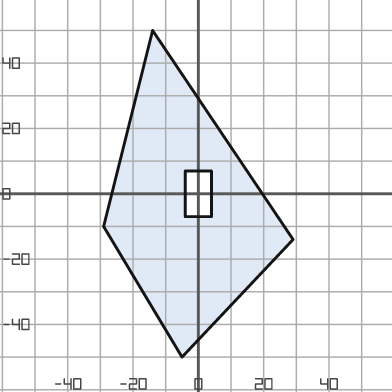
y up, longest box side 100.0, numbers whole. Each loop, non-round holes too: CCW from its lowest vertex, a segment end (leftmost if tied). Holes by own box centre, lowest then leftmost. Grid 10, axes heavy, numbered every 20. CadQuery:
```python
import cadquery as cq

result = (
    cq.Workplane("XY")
    .moveTo(-5.0, -50.0)
    .lineTo(29.0, -14.0)
    .lineTo(-14.0, 50.0)
    .lineTo(-29.0, -10.0)
    .close()
    .moveTo(-4.0, -7.0)
    .lineTo(4.0, -7.0)
    .lineTo(4.0, 7.0)
    .lineTo(-4.0, 7.0)
    .close()
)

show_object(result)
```